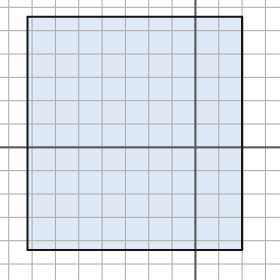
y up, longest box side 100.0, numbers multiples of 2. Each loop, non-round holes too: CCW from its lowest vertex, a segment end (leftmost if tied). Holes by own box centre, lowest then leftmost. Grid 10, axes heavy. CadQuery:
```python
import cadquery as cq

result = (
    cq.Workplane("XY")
    .moveTo(-72.0, -44.0)
    .lineTo(20.0, -44.0)
    .lineTo(20.0, 56.0)
    .lineTo(-72.0, 56.0)
    .close()
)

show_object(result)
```